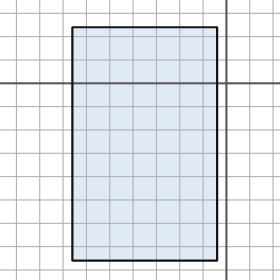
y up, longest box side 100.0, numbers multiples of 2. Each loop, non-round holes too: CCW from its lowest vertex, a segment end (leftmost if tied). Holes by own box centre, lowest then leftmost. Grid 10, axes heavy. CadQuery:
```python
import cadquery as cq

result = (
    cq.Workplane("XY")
    .moveTo(-66.0, -76.0)
    .lineTo(-4.0, -76.0)
    .lineTo(-4.0, 24.0)
    .lineTo(-66.0, 24.0)
    .close()
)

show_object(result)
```